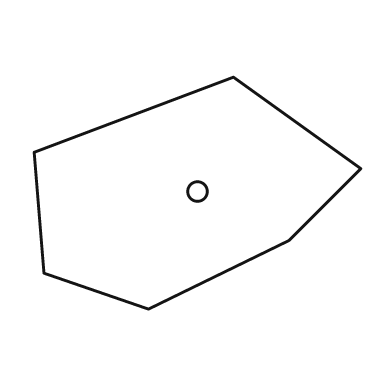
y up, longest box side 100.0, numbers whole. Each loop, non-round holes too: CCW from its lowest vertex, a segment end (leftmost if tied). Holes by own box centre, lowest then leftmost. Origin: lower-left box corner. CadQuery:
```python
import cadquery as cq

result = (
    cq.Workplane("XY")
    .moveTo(35.0, 0.0)
    .lineTo(78.0, 21.0)
    .lineTo(100.0, 43.0)
    .lineTo(61.0, 71.0)
    .lineTo(0.0, 48.0)
    .lineTo(3.0, 11.0)
    .close()
    .moveTo(50.0, 36.0)
    .circle(3.0)
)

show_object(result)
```